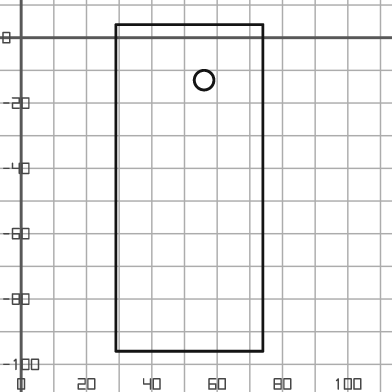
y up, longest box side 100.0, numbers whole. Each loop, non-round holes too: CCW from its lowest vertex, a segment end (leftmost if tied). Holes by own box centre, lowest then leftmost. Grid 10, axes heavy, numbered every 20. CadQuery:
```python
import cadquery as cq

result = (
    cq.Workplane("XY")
    .moveTo(29.0, -96.0)
    .lineTo(74.0, -96.0)
    .lineTo(74.0, 4.0)
    .lineTo(29.0, 4.0)
    .close()
    .moveTo(56.0, -13.0)
    .circle(3.0)
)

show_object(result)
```